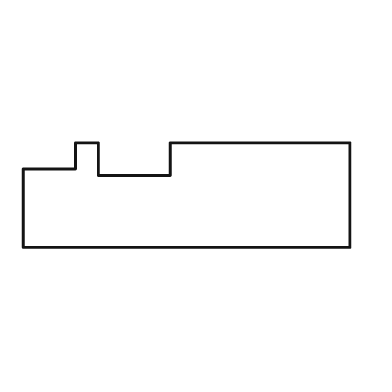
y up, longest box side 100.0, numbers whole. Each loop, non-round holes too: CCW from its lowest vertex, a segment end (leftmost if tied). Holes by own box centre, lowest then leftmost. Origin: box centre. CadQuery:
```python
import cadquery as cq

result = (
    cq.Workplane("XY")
    .moveTo(-50.0, -16.0)
    .lineTo(50.0, -16.0)
    .lineTo(50.0, 16.0)
    .lineTo(-5.0, 16.0)
    .lineTo(-5.0, 6.0)
    .lineTo(-27.0, 6.0)
    .lineTo(-27.0, 16.0)
    .lineTo(-34.0, 16.0)
    .lineTo(-34.0, 8.0)
    .lineTo(-50.0, 8.0)
    .close()
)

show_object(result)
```